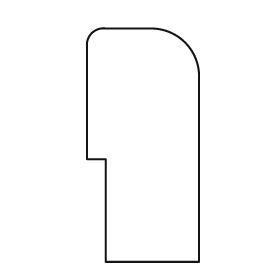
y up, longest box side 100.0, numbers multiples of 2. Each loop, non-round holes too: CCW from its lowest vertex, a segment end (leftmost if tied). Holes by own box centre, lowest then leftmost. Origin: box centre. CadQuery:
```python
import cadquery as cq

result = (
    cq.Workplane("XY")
    .moveTo(-16.0, -50.0)
    .lineTo(24.0, -50.0)
    .lineTo(24.0, 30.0)
    .threePointArc((18.0, 44.0), (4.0, 50.0))
    .lineTo(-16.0, 50.0)
    .threePointArc((-22.0, 48.0), (-24.0, 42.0))
    .lineTo(-24.0, -6.0)
    .lineTo(-16.0, -6.0)
    .close()
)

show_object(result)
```